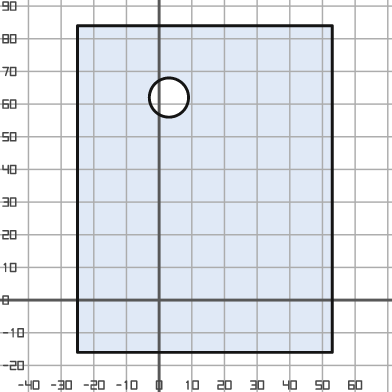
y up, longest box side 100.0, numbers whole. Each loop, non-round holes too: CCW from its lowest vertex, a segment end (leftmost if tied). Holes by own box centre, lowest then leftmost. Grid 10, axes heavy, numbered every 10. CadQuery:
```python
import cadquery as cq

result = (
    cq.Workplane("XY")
    .moveTo(-25.0, -16.0)
    .lineTo(53.0, -16.0)
    .lineTo(53.0, 84.0)
    .lineTo(-25.0, 84.0)
    .close()
    .moveTo(3.0, 62.0)
    .circle(6.0)
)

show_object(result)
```